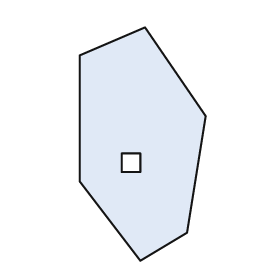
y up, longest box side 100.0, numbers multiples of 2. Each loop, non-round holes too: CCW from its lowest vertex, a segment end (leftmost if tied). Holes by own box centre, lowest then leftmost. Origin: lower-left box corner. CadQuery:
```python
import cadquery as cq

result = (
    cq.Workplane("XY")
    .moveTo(26.0, 0.0)
    .lineTo(46.0, 12.0)
    .lineTo(54.0, 62.0)
    .lineTo(28.0, 100.0)
    .lineTo(0.0, 88.0)
    .lineTo(0.0, 34.0)
    .close()
    .moveTo(18.0, 38.0)
    .lineTo(26.0, 38.0)
    .lineTo(26.0, 46.0)
    .lineTo(18.0, 46.0)
    .close()
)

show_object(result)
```